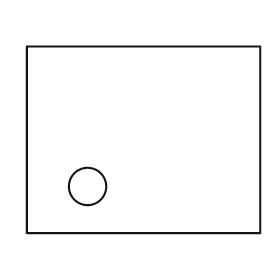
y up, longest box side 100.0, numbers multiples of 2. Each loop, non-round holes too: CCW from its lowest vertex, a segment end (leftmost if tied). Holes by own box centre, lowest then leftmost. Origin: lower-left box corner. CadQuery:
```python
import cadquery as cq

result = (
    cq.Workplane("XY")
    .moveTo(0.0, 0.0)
    .lineTo(100.0, 0.0)
    .lineTo(100.0, 80.0)
    .lineTo(0.0, 80.0)
    .close()
    .moveTo(26.0, 20.0)
    .circle(8.0)
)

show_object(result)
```